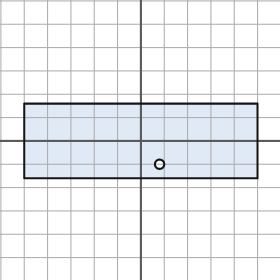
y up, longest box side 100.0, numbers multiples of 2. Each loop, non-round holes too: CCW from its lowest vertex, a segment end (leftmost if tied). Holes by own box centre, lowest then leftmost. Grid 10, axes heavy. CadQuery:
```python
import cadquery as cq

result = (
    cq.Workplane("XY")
    .moveTo(-50.0, -16.0)
    .lineTo(50.0, -16.0)
    .lineTo(50.0, 16.0)
    .lineTo(-50.0, 16.0)
    .close()
    .moveTo(8.0, -10.0)
    .circle(2.0)
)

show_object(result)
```